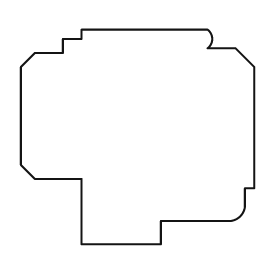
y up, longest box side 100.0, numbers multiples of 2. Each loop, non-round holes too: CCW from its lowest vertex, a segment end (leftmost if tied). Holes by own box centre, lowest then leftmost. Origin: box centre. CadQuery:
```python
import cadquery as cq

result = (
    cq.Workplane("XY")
    .moveTo(-24.0, -46.0)
    .lineTo(10.0, -46.0)
    .lineTo(10.0, -36.0)
    .lineTo(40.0, -36.0)
    .threePointArc((44.0, -34.0), (46.0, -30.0))
    .lineTo(46.0, -22.0)
    .lineTo(50.0, -22.0)
    .lineTo(50.0, 30.0)
    .lineTo(42.0, 38.0)
    .lineTo(30.0, 38.0)
    .threePointArc((32.0, 42.0), (30.0, 46.0))
    .lineTo(-24.0, 46.0)
    .lineTo(-24.0, 42.0)
    .lineTo(-32.0, 42.0)
    .lineTo(-32.0, 36.0)
    .lineTo(-44.0, 36.0)
    .lineTo(-50.0, 30.0)
    .lineTo(-50.0, -12.0)
    .lineTo(-44.0, -18.0)
    .lineTo(-24.0, -18.0)
    .close()
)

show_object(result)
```